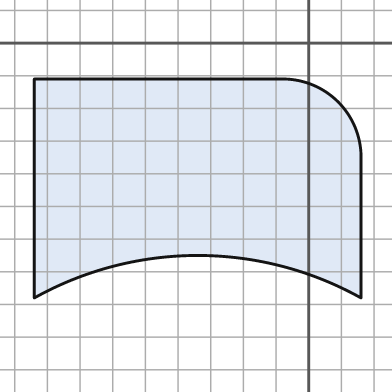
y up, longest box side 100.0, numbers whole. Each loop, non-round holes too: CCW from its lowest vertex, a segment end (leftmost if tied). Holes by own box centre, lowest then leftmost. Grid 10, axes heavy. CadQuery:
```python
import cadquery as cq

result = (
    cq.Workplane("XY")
    .moveTo(-84.0, -78.0)
    .threePointArc((-34.0, -65.0), (16.0, -78.0))
    .lineTo(16.0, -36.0)
    .threePointArc((9.0, -18.0), (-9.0, -11.0))
    .lineTo(-84.0, -11.0)
    .close()
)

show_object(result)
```